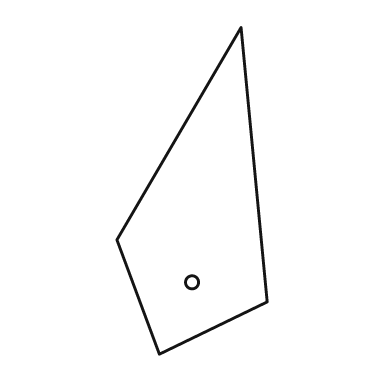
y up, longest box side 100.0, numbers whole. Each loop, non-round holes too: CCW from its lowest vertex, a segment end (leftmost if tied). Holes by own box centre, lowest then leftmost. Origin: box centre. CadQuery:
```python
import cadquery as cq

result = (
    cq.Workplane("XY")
    .moveTo(-10.0, -50.0)
    .lineTo(23.0, -34.0)
    .lineTo(15.0, 50.0)
    .lineTo(-23.0, -15.0)
    .close()
    .moveTo(0.0, -28.0)
    .circle(2.0)
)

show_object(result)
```